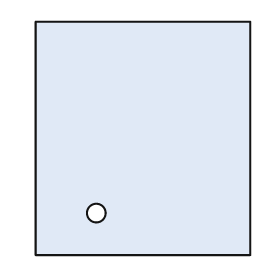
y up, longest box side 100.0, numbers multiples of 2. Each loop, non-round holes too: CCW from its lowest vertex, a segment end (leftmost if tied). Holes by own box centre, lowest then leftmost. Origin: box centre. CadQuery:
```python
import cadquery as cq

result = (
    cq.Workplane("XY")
    .moveTo(-46.0, -50.0)
    .lineTo(46.0, -50.0)
    .lineTo(46.0, 50.0)
    .lineTo(-46.0, 50.0)
    .close()
    .moveTo(-20.0, -32.0)
    .circle(4.0)
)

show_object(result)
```